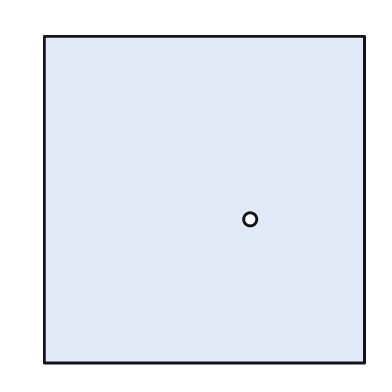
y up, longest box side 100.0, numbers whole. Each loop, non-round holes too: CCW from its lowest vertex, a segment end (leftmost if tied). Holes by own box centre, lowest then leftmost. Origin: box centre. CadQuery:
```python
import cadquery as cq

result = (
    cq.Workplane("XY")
    .moveTo(-49.0, -50.0)
    .lineTo(49.0, -50.0)
    .lineTo(49.0, 50.0)
    .lineTo(-49.0, 50.0)
    .close()
    .moveTo(14.0, -6.0)
    .circle(2.0)
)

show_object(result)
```